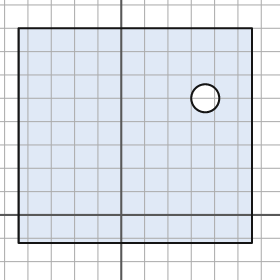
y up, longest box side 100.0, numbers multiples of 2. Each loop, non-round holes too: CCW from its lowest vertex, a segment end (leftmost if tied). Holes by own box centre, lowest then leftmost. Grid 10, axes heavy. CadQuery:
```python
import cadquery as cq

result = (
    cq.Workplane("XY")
    .moveTo(-44.0, -12.0)
    .lineTo(56.0, -12.0)
    .lineTo(56.0, 80.0)
    .lineTo(-44.0, 80.0)
    .close()
    .moveTo(36.0, 50.0)
    .circle(6.0)
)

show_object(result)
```